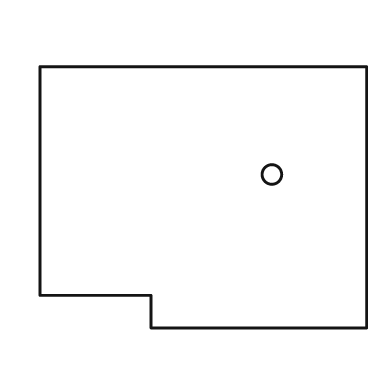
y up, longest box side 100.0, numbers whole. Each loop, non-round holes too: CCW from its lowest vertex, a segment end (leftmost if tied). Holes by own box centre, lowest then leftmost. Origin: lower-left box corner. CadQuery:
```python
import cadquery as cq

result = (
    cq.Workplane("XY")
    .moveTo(34.0, 0.0)
    .lineTo(100.0, 0.0)
    .lineTo(100.0, 80.0)
    .lineTo(0.0, 80.0)
    .lineTo(0.0, 10.0)
    .lineTo(34.0, 10.0)
    .close()
    .moveTo(71.0, 47.0)
    .circle(3.0)
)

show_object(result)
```